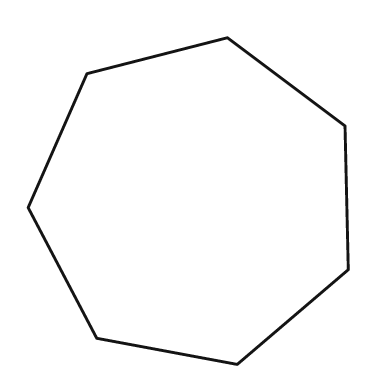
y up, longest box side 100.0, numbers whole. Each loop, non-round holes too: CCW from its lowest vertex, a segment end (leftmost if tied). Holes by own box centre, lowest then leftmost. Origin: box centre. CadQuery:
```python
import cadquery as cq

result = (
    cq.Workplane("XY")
    .moveTo(15.0, -50.0)
    .lineTo(49.0, -21.0)
    .lineTo(48.0, 23.0)
    .lineTo(12.0, 50.0)
    .lineTo(-31.0, 39.0)
    .lineTo(-49.0, -2.0)
    .lineTo(-28.0, -42.0)
    .close()
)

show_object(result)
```